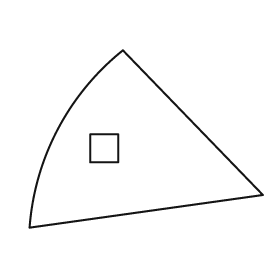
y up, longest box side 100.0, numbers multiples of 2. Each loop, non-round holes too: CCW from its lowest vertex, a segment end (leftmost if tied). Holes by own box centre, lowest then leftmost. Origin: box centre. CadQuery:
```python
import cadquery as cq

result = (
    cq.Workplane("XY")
    .moveTo(-50.0, -38.0)
    .lineTo(50.0, -24.0)
    .lineTo(-10.0, 38.0)
    .threePointArc((-38.0, 4.0), (-50.0, -38.0))
    .close()
    .moveTo(-24.0, -10.0)
    .lineTo(-12.0, -10.0)
    .lineTo(-12.0, 2.0)
    .lineTo(-24.0, 2.0)
    .close()
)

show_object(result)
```